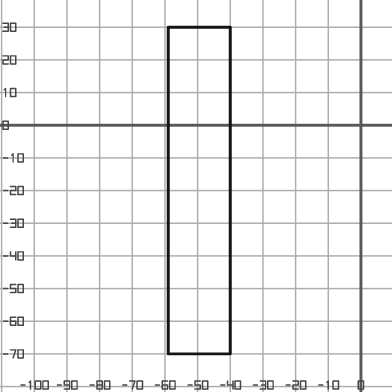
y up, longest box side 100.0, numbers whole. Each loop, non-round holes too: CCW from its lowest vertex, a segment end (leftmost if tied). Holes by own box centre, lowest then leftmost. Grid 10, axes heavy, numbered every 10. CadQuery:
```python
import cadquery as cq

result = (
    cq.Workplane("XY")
    .moveTo(-59.0, -70.0)
    .lineTo(-40.0, -70.0)
    .lineTo(-40.0, 30.0)
    .lineTo(-59.0, 30.0)
    .close()
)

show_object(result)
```